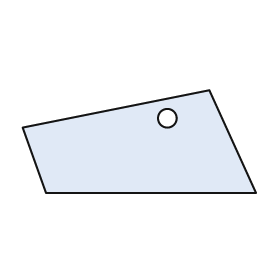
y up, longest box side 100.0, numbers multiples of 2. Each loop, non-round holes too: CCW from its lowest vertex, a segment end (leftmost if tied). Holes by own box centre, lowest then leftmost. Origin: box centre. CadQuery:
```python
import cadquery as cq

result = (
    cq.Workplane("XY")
    .moveTo(-40.0, -22.0)
    .lineTo(50.0, -22.0)
    .lineTo(30.0, 22.0)
    .lineTo(-50.0, 6.0)
    .close()
    .moveTo(12.0, 10.0)
    .circle(4.0)
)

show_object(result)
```